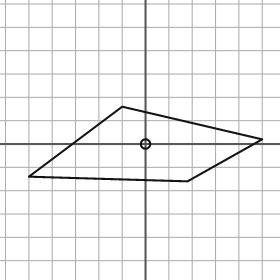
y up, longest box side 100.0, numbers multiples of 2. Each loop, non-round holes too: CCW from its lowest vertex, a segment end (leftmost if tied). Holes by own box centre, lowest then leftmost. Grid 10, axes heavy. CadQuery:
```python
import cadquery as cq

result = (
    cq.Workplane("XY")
    .moveTo(18.0, -16.0)
    .lineTo(50.0, 2.0)
    .lineTo(-10.0, 16.0)
    .lineTo(-50.0, -14.0)
    .close()
    .moveTo(0.0, 0.0)
    .circle(2.0)
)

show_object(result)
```